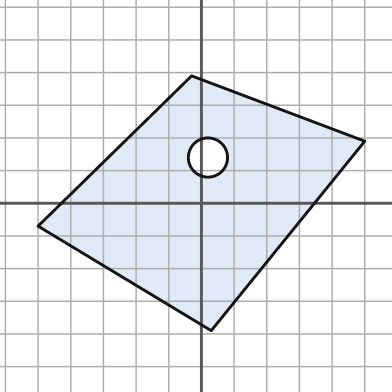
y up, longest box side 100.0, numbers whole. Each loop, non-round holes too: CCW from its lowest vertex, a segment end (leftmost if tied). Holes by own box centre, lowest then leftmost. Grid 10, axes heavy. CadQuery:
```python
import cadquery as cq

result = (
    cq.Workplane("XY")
    .moveTo(3.0, -39.0)
    .lineTo(50.0, 19.0)
    .lineTo(-3.0, 39.0)
    .lineTo(-50.0, -7.0)
    .close()
    .moveTo(2.0, 14.0)
    .circle(6.0)
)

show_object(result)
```